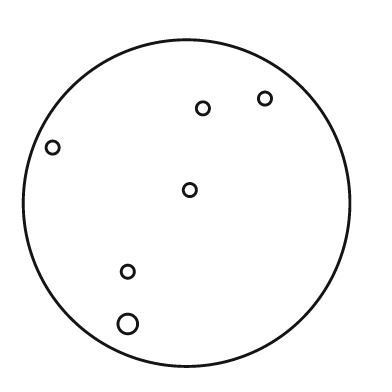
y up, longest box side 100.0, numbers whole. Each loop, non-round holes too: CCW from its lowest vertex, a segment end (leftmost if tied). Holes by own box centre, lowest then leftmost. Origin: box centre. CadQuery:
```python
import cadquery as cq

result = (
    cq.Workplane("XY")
    .moveTo(0.0, 0.0)
    .circle(50.0)
    .moveTo(-18.0, -37.0)
    .circle(3.0)
    .moveTo(-18.0, -21.0)
    .circle(2.0)
    .moveTo(1.0, 4.0)
    .circle(2.0)
    .moveTo(-41.0, 17.0)
    .circle(2.0)
    .moveTo(5.0, 29.0)
    .circle(2.0)
    .moveTo(24.0, 32.0)
    .circle(2.0)
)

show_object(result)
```